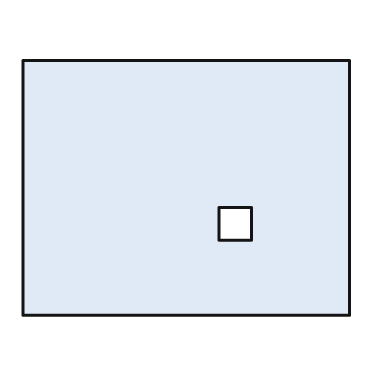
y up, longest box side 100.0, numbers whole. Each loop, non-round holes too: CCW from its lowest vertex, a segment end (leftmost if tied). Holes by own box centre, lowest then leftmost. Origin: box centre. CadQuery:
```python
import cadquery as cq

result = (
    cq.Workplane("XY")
    .moveTo(-50.0, -39.0)
    .lineTo(50.0, -39.0)
    .lineTo(50.0, 39.0)
    .lineTo(-50.0, 39.0)
    .close()
    .moveTo(10.0, -16.0)
    .lineTo(20.0, -16.0)
    .lineTo(20.0, -6.0)
    .lineTo(10.0, -6.0)
    .close()
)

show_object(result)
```